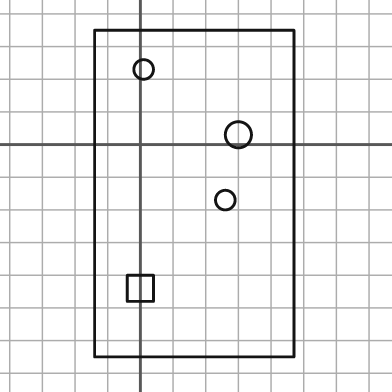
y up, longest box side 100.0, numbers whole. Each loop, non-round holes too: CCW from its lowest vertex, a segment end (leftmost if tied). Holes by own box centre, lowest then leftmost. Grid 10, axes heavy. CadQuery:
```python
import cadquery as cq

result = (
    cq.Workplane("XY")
    .moveTo(-14.0, -65.0)
    .lineTo(47.0, -65.0)
    .lineTo(47.0, 35.0)
    .lineTo(-14.0, 35.0)
    .close()
    .moveTo(-4.0, -48.0)
    .lineTo(4.0, -48.0)
    .lineTo(4.0, -40.0)
    .lineTo(-4.0, -40.0)
    .close()
    .moveTo(26.0, -17.0)
    .circle(3.0)
    .moveTo(30.0, 3.0)
    .circle(4.0)
    .moveTo(1.0, 23.0)
    .circle(3.0)
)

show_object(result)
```